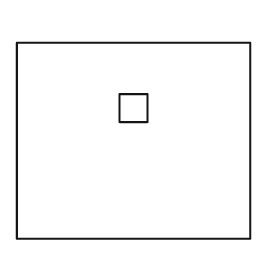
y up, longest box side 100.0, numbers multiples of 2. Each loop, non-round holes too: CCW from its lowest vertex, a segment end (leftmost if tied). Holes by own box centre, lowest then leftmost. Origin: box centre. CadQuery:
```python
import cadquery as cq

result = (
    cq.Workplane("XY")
    .moveTo(-50.0, -42.0)
    .lineTo(50.0, -42.0)
    .lineTo(50.0, 42.0)
    .lineTo(-50.0, 42.0)
    .close()
    .moveTo(-6.0, 8.0)
    .lineTo(6.0, 8.0)
    .lineTo(6.0, 20.0)
    .lineTo(-6.0, 20.0)
    .close()
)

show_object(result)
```